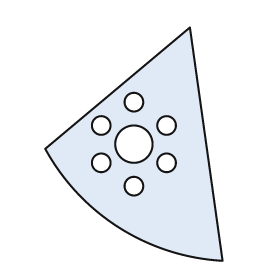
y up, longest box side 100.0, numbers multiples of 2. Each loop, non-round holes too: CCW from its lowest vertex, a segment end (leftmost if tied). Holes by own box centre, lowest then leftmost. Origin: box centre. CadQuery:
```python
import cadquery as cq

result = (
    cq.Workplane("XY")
    .moveTo(38.0, -50.0)
    .lineTo(24.0, 50.0)
    .lineTo(-38.0, -2.0)
    .threePointArc((-6.0, -36.0), (38.0, -50.0))
    .close()
    .moveTo(0.0, -18.0)
    .circle(4.0)
    .moveTo(-14.0, -8.0)
    .circle(4.0)
    .moveTo(14.0, -8.0)
    .circle(4.0)
    .moveTo(0.0, 0.0)
    .circle(8.0)
    .moveTo(-14.0, 8.0)
    .circle(4.0)
    .moveTo(14.0, 8.0)
    .circle(4.0)
    .moveTo(0.0, 18.0)
    .circle(4.0)
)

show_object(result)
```